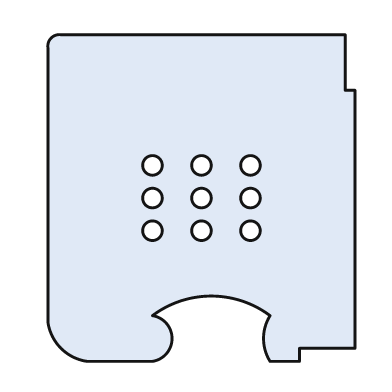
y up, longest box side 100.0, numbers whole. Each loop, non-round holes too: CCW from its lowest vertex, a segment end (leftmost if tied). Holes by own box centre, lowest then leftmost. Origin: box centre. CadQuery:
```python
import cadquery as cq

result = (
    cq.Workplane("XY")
    .moveTo(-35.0, -50.0)
    .lineTo(-15.0, -50.0)
    .threePointArc((-9.0, -43.0), (-15.0, -36.0))
    .threePointArc((3.0, -30.0), (21.0, -36.0))
    .threePointArc((19.0, -43.0), (21.0, -50.0))
    .lineTo(30.0, -50.0)
    .lineTo(30.0, -46.0)
    .lineTo(47.0, -46.0)
    .lineTo(47.0, 33.0)
    .lineTo(44.0, 33.0)
    .lineTo(44.0, 50.0)
    .lineTo(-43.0, 50.0)
    .threePointArc((-46.0, 49.0), (-47.0, 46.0))
    .lineTo(-47.0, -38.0)
    .threePointArc((-43.0, -46.0), (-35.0, -50.0))
    .close()
    .moveTo(-15.0, -10.0)
    .circle(3.0)
    .moveTo(0.0, -10.0)
    .circle(3.0)
    .moveTo(15.0, -10.0)
    .circle(3.0)
    .moveTo(-15.0, 0.0)
    .circle(3.0)
    .moveTo(0.0, 0.0)
    .circle(3.0)
    .moveTo(15.0, 0.0)
    .circle(3.0)
    .moveTo(-15.0, 10.0)
    .circle(3.0)
    .moveTo(0.0, 10.0)
    .circle(3.0)
    .moveTo(15.0, 10.0)
    .circle(3.0)
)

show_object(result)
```